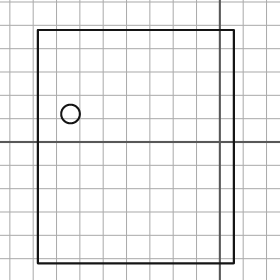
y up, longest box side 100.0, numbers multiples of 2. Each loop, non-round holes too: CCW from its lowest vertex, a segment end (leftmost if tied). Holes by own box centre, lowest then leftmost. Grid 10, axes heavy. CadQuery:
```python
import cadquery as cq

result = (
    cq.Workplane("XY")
    .moveTo(-78.0, -52.0)
    .lineTo(6.0, -52.0)
    .lineTo(6.0, 48.0)
    .lineTo(-78.0, 48.0)
    .close()
    .moveTo(-64.0, 12.0)
    .circle(4.0)
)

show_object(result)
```